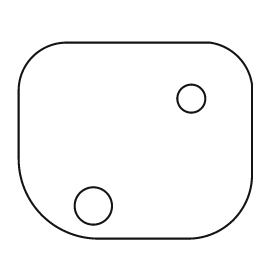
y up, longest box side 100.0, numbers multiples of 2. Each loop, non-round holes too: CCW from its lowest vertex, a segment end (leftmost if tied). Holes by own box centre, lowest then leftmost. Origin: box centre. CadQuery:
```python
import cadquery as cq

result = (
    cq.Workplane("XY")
    .moveTo(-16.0, -42.0)
    .lineTo(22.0, -42.0)
    .threePointArc((42.0, -34.0), (50.0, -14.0))
    .lineTo(50.0, 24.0)
    .threePointArc((44.0, 36.0), (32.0, 42.0))
    .lineTo(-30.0, 42.0)
    .threePointArc((-44.0, 36.0), (-50.0, 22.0))
    .lineTo(-50.0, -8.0)
    .threePointArc((-40.0, -32.0), (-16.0, -42.0))
    .close()
    .moveTo(-18.0, -28.0)
    .circle(8.0)
    .moveTo(24.0, 18.0)
    .circle(6.0)
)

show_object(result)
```